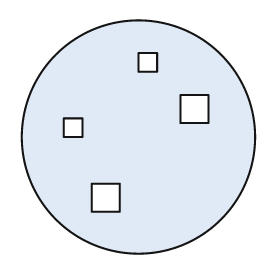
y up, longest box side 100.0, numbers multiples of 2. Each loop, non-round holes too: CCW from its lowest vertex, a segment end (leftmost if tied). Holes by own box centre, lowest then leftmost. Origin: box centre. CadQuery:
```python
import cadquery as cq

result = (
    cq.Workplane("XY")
    .moveTo(0.0, 0.0)
    .circle(50.0)
    .moveTo(-20.0, -32.0)
    .lineTo(-8.0, -32.0)
    .lineTo(-8.0, -20.0)
    .lineTo(-20.0, -20.0)
    .close()
    .moveTo(-32.0, 0.0)
    .lineTo(-24.0, 0.0)
    .lineTo(-24.0, 8.0)
    .lineTo(-32.0, 8.0)
    .close()
    .moveTo(18.0, 6.0)
    .lineTo(30.0, 6.0)
    .lineTo(30.0, 18.0)
    .lineTo(18.0, 18.0)
    .close()
    .moveTo(0.0, 28.0)
    .lineTo(8.0, 28.0)
    .lineTo(8.0, 36.0)
    .lineTo(0.0, 36.0)
    .close()
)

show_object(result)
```